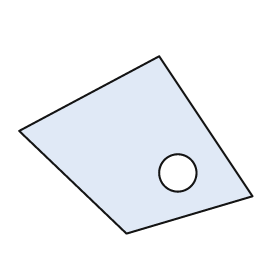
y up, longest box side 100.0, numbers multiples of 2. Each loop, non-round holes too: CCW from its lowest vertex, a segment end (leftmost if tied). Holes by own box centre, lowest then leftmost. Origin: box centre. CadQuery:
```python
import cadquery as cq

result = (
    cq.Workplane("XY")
    .moveTo(-4.0, -38.0)
    .lineTo(50.0, -22.0)
    .lineTo(10.0, 38.0)
    .lineTo(-50.0, 6.0)
    .close()
    .moveTo(18.0, -12.0)
    .circle(8.0)
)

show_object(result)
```